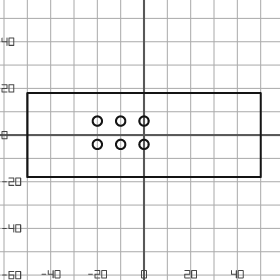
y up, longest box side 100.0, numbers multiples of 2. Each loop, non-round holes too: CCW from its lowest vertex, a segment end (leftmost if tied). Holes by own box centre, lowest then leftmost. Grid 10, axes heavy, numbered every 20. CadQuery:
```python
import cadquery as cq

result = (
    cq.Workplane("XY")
    .moveTo(-50.0, -18.0)
    .lineTo(50.0, -18.0)
    .lineTo(50.0, 18.0)
    .lineTo(-50.0, 18.0)
    .close()
    .moveTo(-20.0, -4.0)
    .circle(2.0)
    .moveTo(-10.0, -4.0)
    .circle(2.0)
    .moveTo(0.0, -4.0)
    .circle(2.0)
    .moveTo(-20.0, 6.0)
    .circle(2.0)
    .moveTo(-10.0, 6.0)
    .circle(2.0)
    .moveTo(0.0, 6.0)
    .circle(2.0)
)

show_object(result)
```